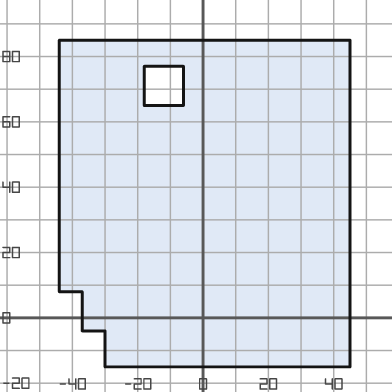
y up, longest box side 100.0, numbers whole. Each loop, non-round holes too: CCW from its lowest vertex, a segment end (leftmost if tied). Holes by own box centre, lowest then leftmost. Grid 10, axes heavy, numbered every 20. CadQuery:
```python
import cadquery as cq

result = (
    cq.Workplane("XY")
    .moveTo(-30.0, -15.0)
    .lineTo(45.0, -15.0)
    .lineTo(45.0, 85.0)
    .lineTo(-44.0, 85.0)
    .lineTo(-44.0, 8.0)
    .lineTo(-37.0, 8.0)
    .lineTo(-37.0, -4.0)
    .lineTo(-30.0, -4.0)
    .close()
    .moveTo(-18.0, 65.0)
    .lineTo(-6.0, 65.0)
    .lineTo(-6.0, 77.0)
    .lineTo(-18.0, 77.0)
    .close()
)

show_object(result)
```